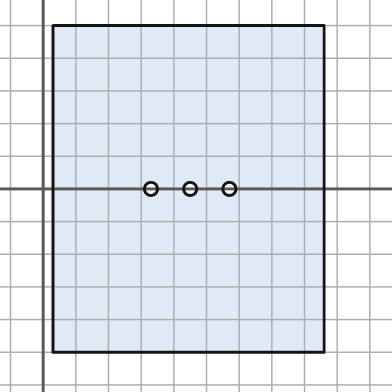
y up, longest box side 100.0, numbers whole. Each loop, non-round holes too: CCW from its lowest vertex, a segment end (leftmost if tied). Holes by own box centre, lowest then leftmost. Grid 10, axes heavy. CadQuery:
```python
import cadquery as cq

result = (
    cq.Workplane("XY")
    .moveTo(3.0, -50.0)
    .lineTo(86.0, -50.0)
    .lineTo(86.0, 50.0)
    .lineTo(3.0, 50.0)
    .close()
    .moveTo(33.0, 0.0)
    .circle(2.0)
    .moveTo(45.0, 0.0)
    .circle(2.0)
    .moveTo(57.0, 0.0)
    .circle(2.0)
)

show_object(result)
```